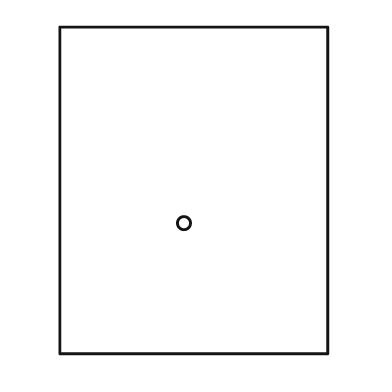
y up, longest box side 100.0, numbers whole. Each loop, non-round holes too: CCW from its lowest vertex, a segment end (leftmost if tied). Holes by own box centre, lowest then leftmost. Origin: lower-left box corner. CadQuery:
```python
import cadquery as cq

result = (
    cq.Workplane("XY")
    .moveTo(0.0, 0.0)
    .lineTo(82.0, 0.0)
    .lineTo(82.0, 100.0)
    .lineTo(0.0, 100.0)
    .close()
    .moveTo(38.0, 40.0)
    .circle(2.0)
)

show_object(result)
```